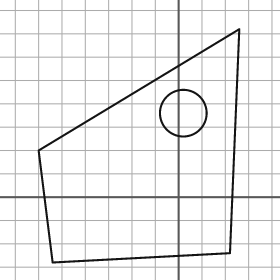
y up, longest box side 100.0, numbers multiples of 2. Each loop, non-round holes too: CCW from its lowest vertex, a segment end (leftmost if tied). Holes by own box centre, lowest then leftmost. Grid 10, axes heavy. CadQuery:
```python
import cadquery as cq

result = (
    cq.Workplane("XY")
    .moveTo(-54.0, -28.0)
    .lineTo(22.0, -24.0)
    .lineTo(26.0, 72.0)
    .lineTo(-60.0, 20.0)
    .close()
    .moveTo(2.0, 36.0)
    .circle(10.0)
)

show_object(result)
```